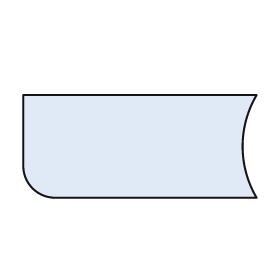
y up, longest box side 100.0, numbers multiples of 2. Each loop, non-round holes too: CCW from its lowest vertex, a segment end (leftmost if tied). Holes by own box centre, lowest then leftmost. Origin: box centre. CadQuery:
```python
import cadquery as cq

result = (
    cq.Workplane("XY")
    .moveTo(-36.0, -22.0)
    .lineTo(50.0, -22.0)
    .threePointArc((44.0, 0.0), (50.0, 22.0))
    .lineTo(-50.0, 22.0)
    .lineTo(-50.0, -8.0)
    .threePointArc((-46.0, -18.0), (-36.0, -22.0))
    .close()
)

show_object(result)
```